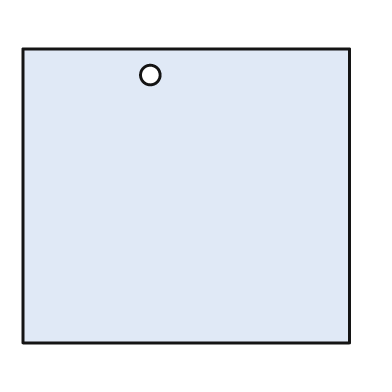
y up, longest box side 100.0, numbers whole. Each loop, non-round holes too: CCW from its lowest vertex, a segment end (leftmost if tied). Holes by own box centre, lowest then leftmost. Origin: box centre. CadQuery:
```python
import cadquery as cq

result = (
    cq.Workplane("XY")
    .moveTo(-50.0, -45.0)
    .lineTo(50.0, -45.0)
    .lineTo(50.0, 45.0)
    .lineTo(-50.0, 45.0)
    .close()
    .moveTo(-11.0, 37.0)
    .circle(3.0)
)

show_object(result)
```